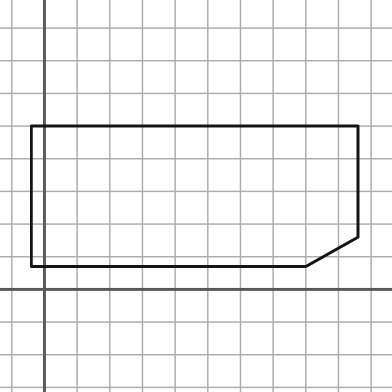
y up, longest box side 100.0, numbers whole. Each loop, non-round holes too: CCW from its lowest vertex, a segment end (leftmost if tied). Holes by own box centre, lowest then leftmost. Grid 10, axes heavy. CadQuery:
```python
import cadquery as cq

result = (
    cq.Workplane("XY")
    .moveTo(-4.0, 7.0)
    .lineTo(80.0, 7.0)
    .lineTo(96.0, 16.0)
    .lineTo(96.0, 50.0)
    .lineTo(-4.0, 50.0)
    .close()
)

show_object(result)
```